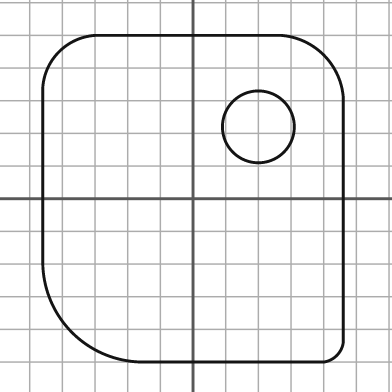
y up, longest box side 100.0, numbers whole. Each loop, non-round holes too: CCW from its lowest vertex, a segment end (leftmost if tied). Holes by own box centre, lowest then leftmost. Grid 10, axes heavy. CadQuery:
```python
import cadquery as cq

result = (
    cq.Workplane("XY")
    .moveTo(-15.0, -50.0)
    .lineTo(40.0, -50.0)
    .threePointArc((44.0, -48.0), (46.0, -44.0))
    .lineTo(46.0, 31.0)
    .threePointArc((40.0, 44.0), (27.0, 50.0))
    .lineTo(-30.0, 50.0)
    .threePointArc((-41.0, 45.0), (-46.0, 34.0))
    .lineTo(-46.0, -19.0)
    .threePointArc((-37.0, -41.0), (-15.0, -50.0))
    .close()
    .moveTo(20.0, 22.0)
    .circle(11.0)
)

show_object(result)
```